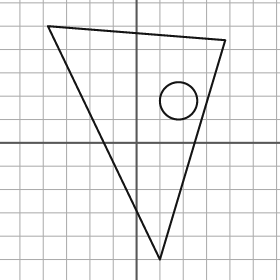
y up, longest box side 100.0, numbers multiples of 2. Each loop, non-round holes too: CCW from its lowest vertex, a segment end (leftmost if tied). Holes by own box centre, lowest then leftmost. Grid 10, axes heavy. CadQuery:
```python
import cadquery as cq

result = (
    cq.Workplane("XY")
    .moveTo(10.0, -50.0)
    .lineTo(38.0, 44.0)
    .lineTo(-38.0, 50.0)
    .close()
    .moveTo(18.0, 18.0)
    .circle(8.0)
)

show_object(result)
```